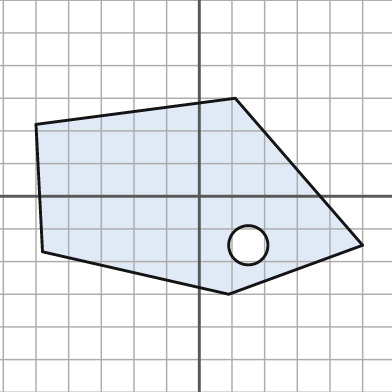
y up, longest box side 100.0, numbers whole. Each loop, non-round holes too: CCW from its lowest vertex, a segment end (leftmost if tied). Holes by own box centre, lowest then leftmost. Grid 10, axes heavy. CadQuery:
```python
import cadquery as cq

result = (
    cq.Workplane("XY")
    .moveTo(9.0, -30.0)
    .lineTo(50.0, -15.0)
    .lineTo(11.0, 30.0)
    .lineTo(-50.0, 22.0)
    .lineTo(-48.0, -17.0)
    .close()
    .moveTo(15.0, -15.0)
    .circle(6.0)
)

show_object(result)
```